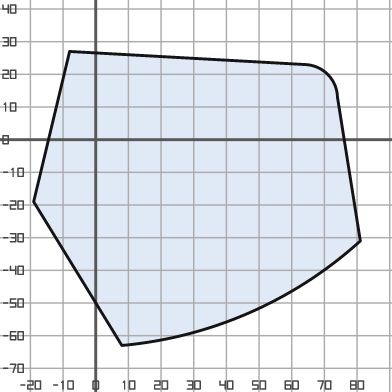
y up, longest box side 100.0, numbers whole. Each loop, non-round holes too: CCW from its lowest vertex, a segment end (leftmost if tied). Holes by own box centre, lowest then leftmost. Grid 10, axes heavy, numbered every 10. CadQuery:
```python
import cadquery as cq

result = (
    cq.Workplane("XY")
    .moveTo(8.0, -63.0)
    .threePointArc((47.0, -53.0), (81.0, -31.0))
    .lineTo(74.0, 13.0)
    .threePointArc((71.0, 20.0), (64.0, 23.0))
    .lineTo(-8.0, 27.0)
    .lineTo(-19.0, -19.0)
    .close()
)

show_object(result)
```